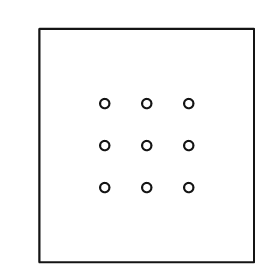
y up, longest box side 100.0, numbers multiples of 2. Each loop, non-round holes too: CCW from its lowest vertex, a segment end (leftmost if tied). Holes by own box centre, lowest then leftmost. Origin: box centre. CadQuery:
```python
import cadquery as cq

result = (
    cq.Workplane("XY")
    .moveTo(-46.0, -50.0)
    .lineTo(46.0, -50.0)
    .lineTo(46.0, 50.0)
    .lineTo(-46.0, 50.0)
    .close()
    .moveTo(-18.0, -18.0)
    .circle(2.0)
    .moveTo(0.0, -18.0)
    .circle(2.0)
    .moveTo(18.0, -18.0)
    .circle(2.0)
    .moveTo(-18.0, 0.0)
    .circle(2.0)
    .moveTo(0.0, 0.0)
    .circle(2.0)
    .moveTo(18.0, 0.0)
    .circle(2.0)
    .moveTo(-18.0, 18.0)
    .circle(2.0)
    .moveTo(0.0, 18.0)
    .circle(2.0)
    .moveTo(18.0, 18.0)
    .circle(2.0)
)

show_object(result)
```